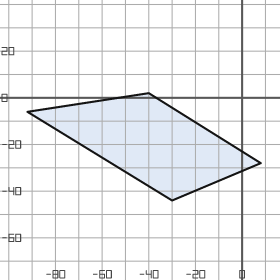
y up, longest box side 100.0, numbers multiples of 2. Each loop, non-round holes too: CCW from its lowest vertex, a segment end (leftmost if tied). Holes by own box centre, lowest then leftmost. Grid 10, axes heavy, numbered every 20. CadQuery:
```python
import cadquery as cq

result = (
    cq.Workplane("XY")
    .moveTo(-30.0, -44.0)
    .lineTo(8.0, -28.0)
    .lineTo(-40.0, 2.0)
    .lineTo(-92.0, -6.0)
    .close()
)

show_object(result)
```